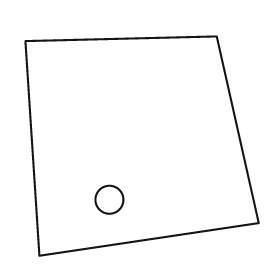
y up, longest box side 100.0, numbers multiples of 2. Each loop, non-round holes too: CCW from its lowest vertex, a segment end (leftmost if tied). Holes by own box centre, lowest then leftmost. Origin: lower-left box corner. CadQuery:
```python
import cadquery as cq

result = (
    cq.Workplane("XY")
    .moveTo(6.0, 0.0)
    .lineTo(100.0, 14.0)
    .lineTo(82.0, 94.0)
    .lineTo(0.0, 92.0)
    .close()
    .moveTo(36.0, 24.0)
    .circle(6.0)
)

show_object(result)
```